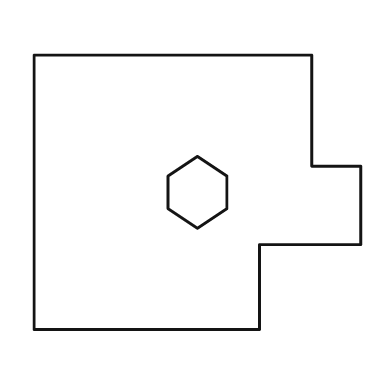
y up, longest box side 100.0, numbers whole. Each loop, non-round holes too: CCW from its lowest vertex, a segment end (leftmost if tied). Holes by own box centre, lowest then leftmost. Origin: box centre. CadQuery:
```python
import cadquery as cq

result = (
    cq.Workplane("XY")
    .moveTo(-50.0, -42.0)
    .lineTo(19.0, -42.0)
    .lineTo(19.0, -16.0)
    .lineTo(50.0, -16.0)
    .lineTo(50.0, 8.0)
    .lineTo(35.0, 8.0)
    .lineTo(35.0, 42.0)
    .lineTo(-50.0, 42.0)
    .close()
    .moveTo(0.0, -11.0)
    .lineTo(9.0, -5.0)
    .lineTo(9.0, 5.0)
    .lineTo(0.0, 11.0)
    .lineTo(-9.0, 5.0)
    .lineTo(-9.0, -5.0)
    .close()
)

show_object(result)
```